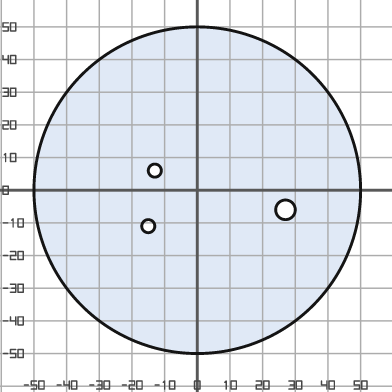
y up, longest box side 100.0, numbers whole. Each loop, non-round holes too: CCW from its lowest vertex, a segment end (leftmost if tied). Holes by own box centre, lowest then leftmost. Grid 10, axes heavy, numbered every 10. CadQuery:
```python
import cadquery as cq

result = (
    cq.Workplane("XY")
    .moveTo(0.0, 0.0)
    .circle(50.0)
    .moveTo(-15.0, -11.0)
    .circle(2.0)
    .moveTo(27.0, -6.0)
    .circle(3.0)
    .moveTo(-13.0, 6.0)
    .circle(2.0)
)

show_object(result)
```